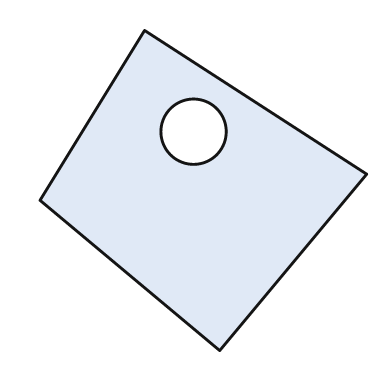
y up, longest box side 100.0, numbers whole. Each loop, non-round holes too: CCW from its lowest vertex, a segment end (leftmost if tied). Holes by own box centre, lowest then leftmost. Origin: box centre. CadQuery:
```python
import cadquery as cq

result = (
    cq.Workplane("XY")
    .moveTo(5.0, -49.0)
    .lineTo(50.0, 5.0)
    .lineTo(-18.0, 49.0)
    .lineTo(-50.0, -3.0)
    .close()
    .moveTo(-3.0, 18.0)
    .circle(10.0)
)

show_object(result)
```